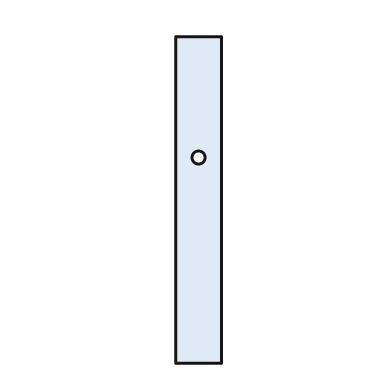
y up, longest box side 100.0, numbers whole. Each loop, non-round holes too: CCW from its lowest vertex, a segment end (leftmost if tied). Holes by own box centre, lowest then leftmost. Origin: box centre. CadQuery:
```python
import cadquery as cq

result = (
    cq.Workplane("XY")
    .moveTo(-7.0, -50.0)
    .lineTo(7.0, -50.0)
    .lineTo(7.0, 50.0)
    .lineTo(-7.0, 50.0)
    .close()
    .moveTo(0.0, 13.0)
    .circle(2.0)
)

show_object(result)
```